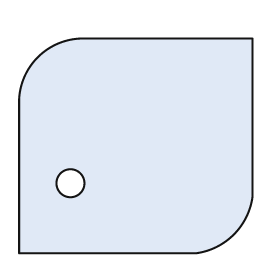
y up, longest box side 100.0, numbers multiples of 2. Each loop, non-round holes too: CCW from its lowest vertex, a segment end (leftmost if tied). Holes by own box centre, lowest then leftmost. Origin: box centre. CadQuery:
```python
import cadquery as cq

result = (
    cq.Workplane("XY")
    .moveTo(-50.0, -46.0)
    .lineTo(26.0, -46.0)
    .threePointArc((42.0, -38.0), (50.0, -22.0))
    .lineTo(50.0, 46.0)
    .lineTo(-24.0, 46.0)
    .threePointArc((-42.0, 38.0), (-50.0, 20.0))
    .close()
    .moveTo(-28.0, -16.0)
    .circle(6.0)
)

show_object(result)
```